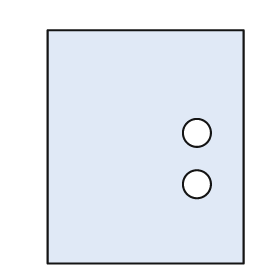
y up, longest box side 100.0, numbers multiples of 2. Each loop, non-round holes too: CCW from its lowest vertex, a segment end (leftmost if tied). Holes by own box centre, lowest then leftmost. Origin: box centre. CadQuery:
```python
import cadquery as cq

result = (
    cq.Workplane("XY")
    .moveTo(-42.0, -50.0)
    .lineTo(42.0, -50.0)
    .lineTo(42.0, 50.0)
    .lineTo(-42.0, 50.0)
    .close()
    .moveTo(22.0, -16.0)
    .circle(6.0)
    .moveTo(22.0, 6.0)
    .circle(6.0)
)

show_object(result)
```